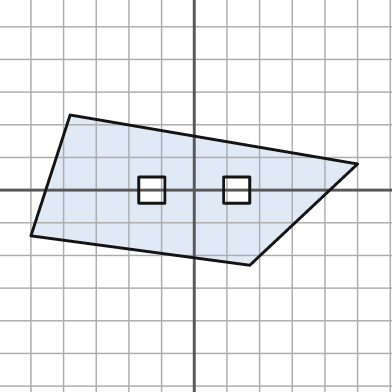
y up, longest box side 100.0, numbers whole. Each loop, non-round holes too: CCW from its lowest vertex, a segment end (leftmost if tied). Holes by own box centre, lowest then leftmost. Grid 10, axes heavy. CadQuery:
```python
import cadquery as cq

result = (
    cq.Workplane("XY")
    .moveTo(17.0, -23.0)
    .lineTo(50.0, 8.0)
    .lineTo(-38.0, 23.0)
    .lineTo(-50.0, -14.0)
    .close()
    .moveTo(-17.0, -4.0)
    .lineTo(-9.0, -4.0)
    .lineTo(-9.0, 4.0)
    .lineTo(-17.0, 4.0)
    .close()
    .moveTo(9.0, -4.0)
    .lineTo(17.0, -4.0)
    .lineTo(17.0, 4.0)
    .lineTo(9.0, 4.0)
    .close()
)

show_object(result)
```